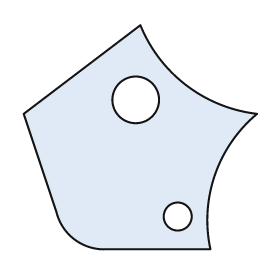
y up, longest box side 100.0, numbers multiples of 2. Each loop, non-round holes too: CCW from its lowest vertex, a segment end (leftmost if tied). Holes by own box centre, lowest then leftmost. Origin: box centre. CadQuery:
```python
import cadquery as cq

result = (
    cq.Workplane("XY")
    .moveTo(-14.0, -48.0)
    .lineTo(30.0, -48.0)
    .threePointArc((32.0, -16.0), (50.0, 10.0))
    .threePointArc((20.0, 22.0), (0.0, 48.0))
    .lineTo(-50.0, 10.0)
    .lineTo(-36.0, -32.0)
    .threePointArc((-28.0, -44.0), (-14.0, -48.0))
    .close()
    .moveTo(16.0, -34.0)
    .circle(6.0)
    .moveTo(-2.0, 16.0)
    .circle(10.0)
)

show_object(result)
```